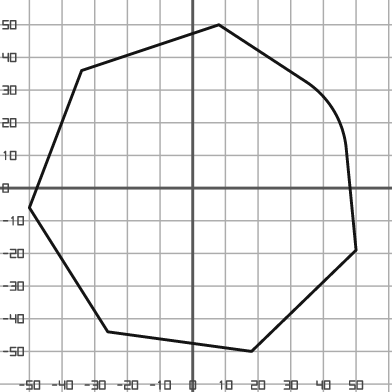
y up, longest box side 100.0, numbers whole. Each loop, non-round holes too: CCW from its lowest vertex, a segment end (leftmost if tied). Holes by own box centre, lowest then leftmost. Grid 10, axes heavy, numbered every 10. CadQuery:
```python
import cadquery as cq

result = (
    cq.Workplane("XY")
    .moveTo(18.0, -50.0)
    .lineTo(50.0, -19.0)
    .lineTo(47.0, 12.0)
    .threePointArc((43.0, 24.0), (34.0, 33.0))
    .lineTo(8.0, 50.0)
    .lineTo(-34.0, 36.0)
    .lineTo(-50.0, -6.0)
    .lineTo(-26.0, -44.0)
    .close()
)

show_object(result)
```